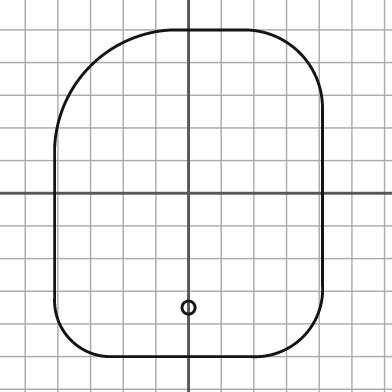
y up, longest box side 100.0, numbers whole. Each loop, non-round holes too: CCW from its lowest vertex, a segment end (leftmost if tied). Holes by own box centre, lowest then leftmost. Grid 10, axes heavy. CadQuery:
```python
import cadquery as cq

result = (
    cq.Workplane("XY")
    .moveTo(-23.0, -50.0)
    .lineTo(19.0, -50.0)
    .threePointArc((35.0, -44.0), (41.0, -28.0))
    .lineTo(41.0, 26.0)
    .threePointArc((34.0, 43.0), (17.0, 50.0))
    .lineTo(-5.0, 50.0)
    .threePointArc((-30.0, 39.0), (-41.0, 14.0))
    .lineTo(-41.0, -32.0)
    .threePointArc((-36.0, -45.0), (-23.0, -50.0))
    .close()
    .moveTo(0.0, -35.0)
    .circle(2.0)
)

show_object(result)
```